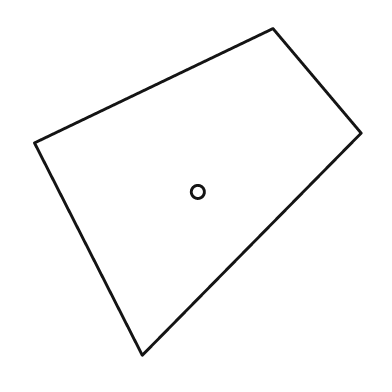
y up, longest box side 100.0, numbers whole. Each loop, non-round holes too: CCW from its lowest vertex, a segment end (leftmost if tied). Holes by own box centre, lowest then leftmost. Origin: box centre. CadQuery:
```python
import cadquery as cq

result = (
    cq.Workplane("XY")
    .moveTo(-17.0, -50.0)
    .lineTo(50.0, 18.0)
    .lineTo(23.0, 50.0)
    .lineTo(-50.0, 15.0)
    .close()
    .moveTo(0.0, 0.0)
    .circle(2.0)
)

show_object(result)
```